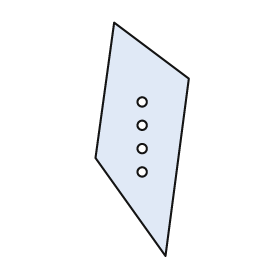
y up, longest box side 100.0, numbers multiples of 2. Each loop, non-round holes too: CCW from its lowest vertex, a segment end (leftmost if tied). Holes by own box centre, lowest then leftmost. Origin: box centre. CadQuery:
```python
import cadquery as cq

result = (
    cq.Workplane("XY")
    .moveTo(10.0, -50.0)
    .lineTo(20.0, 26.0)
    .lineTo(-12.0, 50.0)
    .lineTo(-20.0, -8.0)
    .close()
    .moveTo(0.0, -14.0)
    .circle(2.0)
    .moveTo(0.0, -4.0)
    .circle(2.0)
    .moveTo(0.0, 6.0)
    .circle(2.0)
    .moveTo(0.0, 16.0)
    .circle(2.0)
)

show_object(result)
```